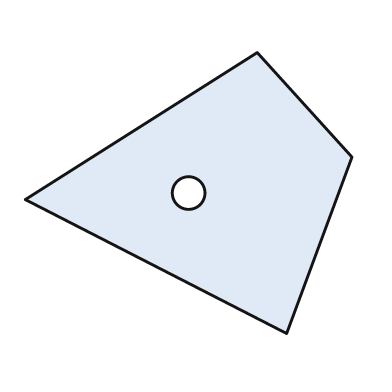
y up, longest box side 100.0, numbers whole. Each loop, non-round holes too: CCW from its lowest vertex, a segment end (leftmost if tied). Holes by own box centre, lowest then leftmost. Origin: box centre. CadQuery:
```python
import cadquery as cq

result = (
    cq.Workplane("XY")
    .moveTo(30.0, -43.0)
    .lineTo(50.0, 11.0)
    .lineTo(21.0, 43.0)
    .lineTo(-50.0, -2.0)
    .close()
    .moveTo(0.0, 0.0)
    .circle(5.0)
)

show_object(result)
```